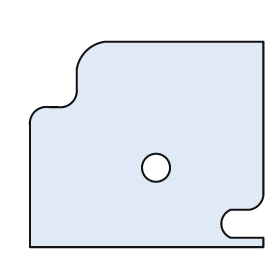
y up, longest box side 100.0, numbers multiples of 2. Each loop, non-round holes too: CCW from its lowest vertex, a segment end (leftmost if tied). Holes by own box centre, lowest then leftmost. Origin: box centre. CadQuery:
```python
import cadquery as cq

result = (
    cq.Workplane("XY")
    .moveTo(-50.0, -44.0)
    .lineTo(50.0, -44.0)
    .lineTo(50.0, -40.0)
    .lineTo(36.0, -40.0)
    .threePointArc((32.0, -34.0), (36.0, -28.0))
    .lineTo(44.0, -28.0)
    .threePointArc((48.0, -26.0), (50.0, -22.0))
    .lineTo(50.0, 44.0)
    .lineTo(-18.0, 44.0)
    .threePointArc((-26.0, 40.0), (-30.0, 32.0))
    .lineTo(-30.0, 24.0)
    .threePointArc((-32.0, 18.0), (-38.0, 16.0))
    .lineTo(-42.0, 16.0)
    .threePointArc((-48.0, 14.0), (-50.0, 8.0))
    .close()
    .moveTo(4.0, -10.0)
    .circle(6.0)
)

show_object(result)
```